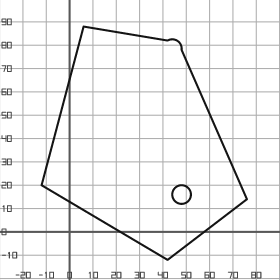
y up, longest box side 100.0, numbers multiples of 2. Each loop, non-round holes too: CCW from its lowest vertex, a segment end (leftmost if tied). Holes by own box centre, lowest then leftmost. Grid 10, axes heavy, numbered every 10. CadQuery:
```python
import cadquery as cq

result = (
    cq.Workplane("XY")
    .moveTo(42.0, -12.0)
    .lineTo(76.0, 14.0)
    .lineTo(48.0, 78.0)
    .threePointArc((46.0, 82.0), (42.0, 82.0))
    .lineTo(6.0, 88.0)
    .lineTo(-12.0, 20.0)
    .close()
    .moveTo(48.0, 16.0)
    .circle(4.0)
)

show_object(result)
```